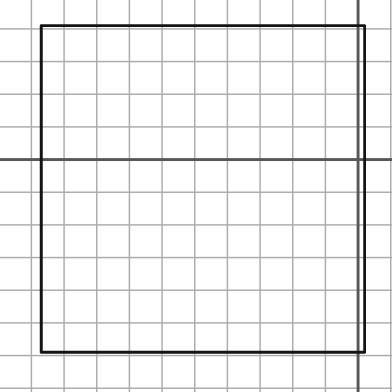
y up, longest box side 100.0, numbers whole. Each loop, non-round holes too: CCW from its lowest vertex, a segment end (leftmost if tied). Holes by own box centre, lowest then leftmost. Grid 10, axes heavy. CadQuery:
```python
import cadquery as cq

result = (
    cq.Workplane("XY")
    .moveTo(-97.0, -59.0)
    .lineTo(2.0, -59.0)
    .lineTo(2.0, 41.0)
    .lineTo(-97.0, 41.0)
    .close()
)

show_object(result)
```